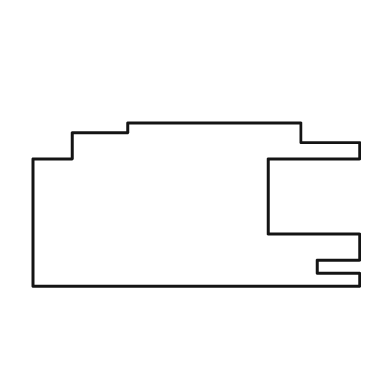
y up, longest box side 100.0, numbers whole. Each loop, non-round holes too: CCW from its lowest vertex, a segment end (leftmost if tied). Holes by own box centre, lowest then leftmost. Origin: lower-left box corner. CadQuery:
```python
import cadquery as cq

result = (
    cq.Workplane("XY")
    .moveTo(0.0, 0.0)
    .lineTo(100.0, 0.0)
    .lineTo(100.0, 4.0)
    .lineTo(87.0, 4.0)
    .lineTo(87.0, 8.0)
    .lineTo(100.0, 8.0)
    .lineTo(100.0, 16.0)
    .lineTo(72.0, 16.0)
    .lineTo(72.0, 39.0)
    .lineTo(100.0, 39.0)
    .lineTo(100.0, 44.0)
    .lineTo(82.0, 44.0)
    .lineTo(82.0, 50.0)
    .lineTo(29.0, 50.0)
    .lineTo(29.0, 47.0)
    .lineTo(12.0, 47.0)
    .lineTo(12.0, 39.0)
    .lineTo(0.0, 39.0)
    .close()
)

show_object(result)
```